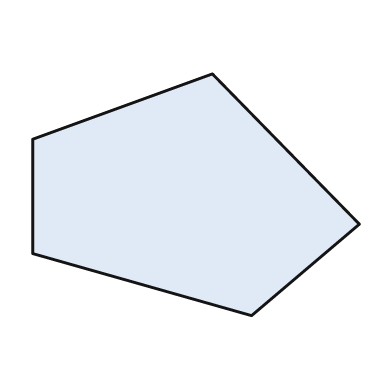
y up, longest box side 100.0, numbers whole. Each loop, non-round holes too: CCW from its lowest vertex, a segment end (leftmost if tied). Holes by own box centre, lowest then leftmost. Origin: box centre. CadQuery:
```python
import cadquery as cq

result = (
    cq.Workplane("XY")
    .moveTo(17.0, -37.0)
    .lineTo(50.0, -9.0)
    .lineTo(5.0, 37.0)
    .lineTo(-50.0, 17.0)
    .lineTo(-50.0, -18.0)
    .close()
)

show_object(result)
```